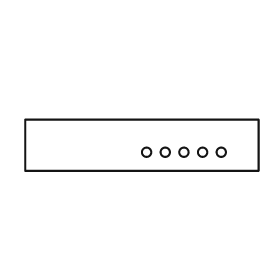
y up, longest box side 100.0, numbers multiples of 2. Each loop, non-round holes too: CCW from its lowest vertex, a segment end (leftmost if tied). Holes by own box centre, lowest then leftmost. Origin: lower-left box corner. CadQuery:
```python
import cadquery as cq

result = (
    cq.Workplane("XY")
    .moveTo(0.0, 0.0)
    .lineTo(100.0, 0.0)
    .lineTo(100.0, 22.0)
    .lineTo(0.0, 22.0)
    .close()
    .moveTo(52.0, 8.0)
    .circle(2.0)
    .moveTo(60.0, 8.0)
    .circle(2.0)
    .moveTo(68.0, 8.0)
    .circle(2.0)
    .moveTo(76.0, 8.0)
    .circle(2.0)
    .moveTo(84.0, 8.0)
    .circle(2.0)
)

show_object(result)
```